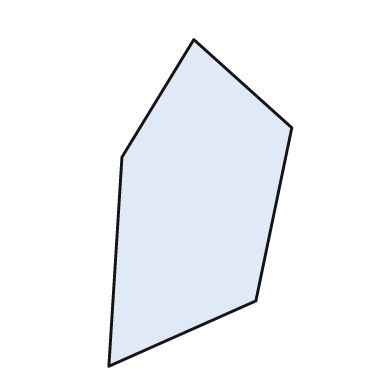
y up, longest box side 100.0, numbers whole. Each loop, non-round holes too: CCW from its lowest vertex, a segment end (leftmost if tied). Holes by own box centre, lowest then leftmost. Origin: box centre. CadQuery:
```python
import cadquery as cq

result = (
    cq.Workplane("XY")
    .moveTo(-28.0, -50.0)
    .lineTo(17.0, -30.0)
    .lineTo(28.0, 23.0)
    .lineTo(-2.0, 50.0)
    .lineTo(-24.0, 14.0)
    .close()
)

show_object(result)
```